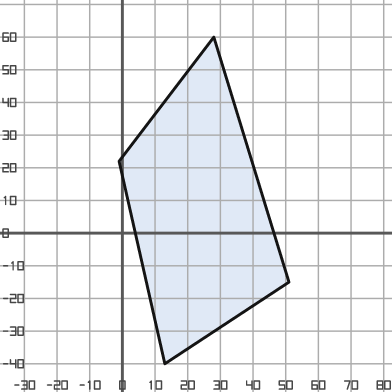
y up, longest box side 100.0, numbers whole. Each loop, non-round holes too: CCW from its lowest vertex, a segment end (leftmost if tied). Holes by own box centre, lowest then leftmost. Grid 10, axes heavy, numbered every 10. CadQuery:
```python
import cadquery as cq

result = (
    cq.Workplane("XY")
    .moveTo(13.0, -40.0)
    .lineTo(51.0, -15.0)
    .lineTo(28.0, 60.0)
    .lineTo(-1.0, 22.0)
    .close()
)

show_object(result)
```